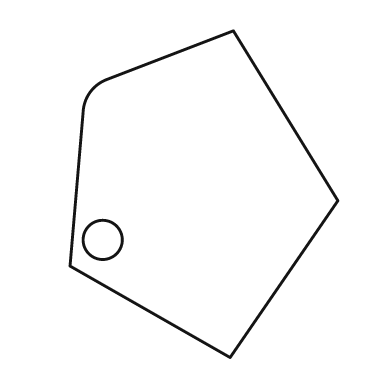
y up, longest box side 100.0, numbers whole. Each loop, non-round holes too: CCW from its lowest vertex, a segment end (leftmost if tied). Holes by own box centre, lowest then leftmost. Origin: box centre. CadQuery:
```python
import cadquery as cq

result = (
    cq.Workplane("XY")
    .moveTo(8.0, -50.0)
    .lineTo(41.0, -2.0)
    .lineTo(9.0, 50.0)
    .lineTo(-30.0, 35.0)
    .threePointArc((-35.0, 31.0), (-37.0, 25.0))
    .lineTo(-41.0, -22.0)
    .close()
    .moveTo(-31.0, -14.0)
    .circle(6.0)
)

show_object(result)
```